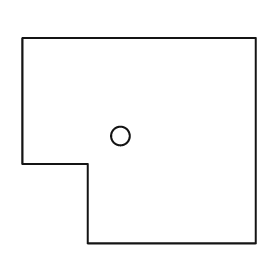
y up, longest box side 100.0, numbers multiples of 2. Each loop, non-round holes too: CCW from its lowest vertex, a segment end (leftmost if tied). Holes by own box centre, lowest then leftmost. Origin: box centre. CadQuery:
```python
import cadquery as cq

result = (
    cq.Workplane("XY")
    .moveTo(-22.0, -44.0)
    .lineTo(50.0, -44.0)
    .lineTo(50.0, 44.0)
    .lineTo(-50.0, 44.0)
    .lineTo(-50.0, -10.0)
    .lineTo(-22.0, -10.0)
    .close()
    .moveTo(-8.0, 2.0)
    .circle(4.0)
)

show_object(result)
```